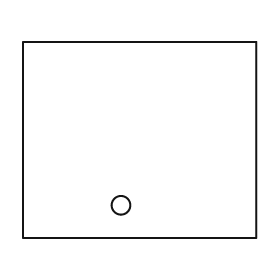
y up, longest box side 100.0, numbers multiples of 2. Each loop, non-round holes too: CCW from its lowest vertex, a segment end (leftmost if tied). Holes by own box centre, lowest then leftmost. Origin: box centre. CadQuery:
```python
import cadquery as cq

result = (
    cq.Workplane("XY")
    .moveTo(-50.0, -42.0)
    .lineTo(50.0, -42.0)
    .lineTo(50.0, 42.0)
    .lineTo(-50.0, 42.0)
    .close()
    .moveTo(-8.0, -28.0)
    .circle(4.0)
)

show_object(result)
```